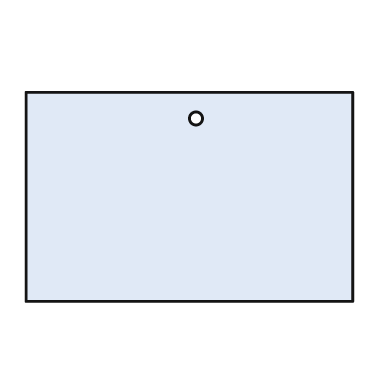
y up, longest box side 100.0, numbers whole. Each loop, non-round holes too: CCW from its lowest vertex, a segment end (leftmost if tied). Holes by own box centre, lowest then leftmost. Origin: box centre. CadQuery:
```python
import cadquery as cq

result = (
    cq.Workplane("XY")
    .moveTo(-50.0, -32.0)
    .lineTo(50.0, -32.0)
    .lineTo(50.0, 32.0)
    .lineTo(-50.0, 32.0)
    .close()
    .moveTo(2.0, 24.0)
    .circle(2.0)
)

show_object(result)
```